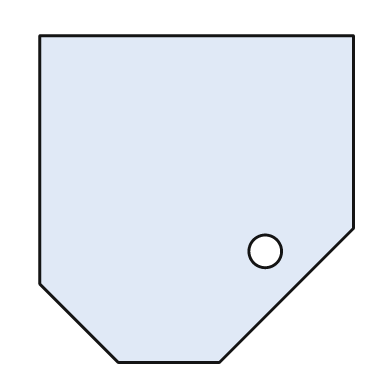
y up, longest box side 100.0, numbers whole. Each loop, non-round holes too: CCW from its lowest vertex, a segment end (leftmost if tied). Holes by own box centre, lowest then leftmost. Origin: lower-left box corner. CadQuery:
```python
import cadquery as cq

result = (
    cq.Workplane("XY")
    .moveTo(24.0, 0.0)
    .lineTo(55.0, 0.0)
    .lineTo(96.0, 41.0)
    .lineTo(96.0, 100.0)
    .lineTo(0.0, 100.0)
    .lineTo(0.0, 24.0)
    .close()
    .moveTo(69.0, 34.0)
    .circle(5.0)
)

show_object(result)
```